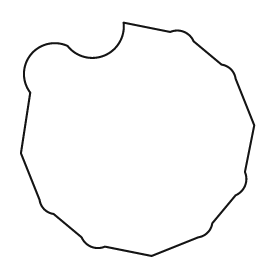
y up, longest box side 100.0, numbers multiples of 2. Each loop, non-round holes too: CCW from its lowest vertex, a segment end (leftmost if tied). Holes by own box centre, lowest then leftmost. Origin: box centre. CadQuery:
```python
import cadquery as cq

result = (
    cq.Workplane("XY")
    .moveTo(6.0, -50.0)
    .lineTo(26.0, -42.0)
    .threePointArc((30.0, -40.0), (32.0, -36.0))
    .lineTo(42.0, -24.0)
    .threePointArc((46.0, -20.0), (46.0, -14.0))
    .lineTo(50.0, 6.0)
    .lineTo(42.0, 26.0)
    .threePointArc((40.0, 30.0), (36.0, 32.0))
    .lineTo(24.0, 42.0)
    .threePointArc((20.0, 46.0), (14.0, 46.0))
    .lineTo(-6.0, 50.0)
    .threePointArc((-14.0, 36.0), (-30.0, 40.0))
    .threePointArc((-46.0, 36.0), (-46.0, 20.0))
    .lineTo(-50.0, -6.0)
    .lineTo(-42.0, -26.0)
    .threePointArc((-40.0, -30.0), (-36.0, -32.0))
    .lineTo(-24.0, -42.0)
    .threePointArc((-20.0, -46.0), (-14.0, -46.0))
    .close()
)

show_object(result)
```